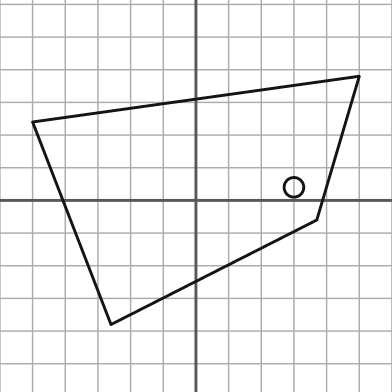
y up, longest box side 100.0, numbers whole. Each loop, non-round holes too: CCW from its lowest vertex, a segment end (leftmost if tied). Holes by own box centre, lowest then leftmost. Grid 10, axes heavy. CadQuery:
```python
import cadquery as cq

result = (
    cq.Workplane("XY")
    .moveTo(-26.0, -38.0)
    .lineTo(37.0, -6.0)
    .lineTo(50.0, 38.0)
    .lineTo(-50.0, 24.0)
    .close()
    .moveTo(30.0, 4.0)
    .circle(3.0)
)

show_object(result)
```